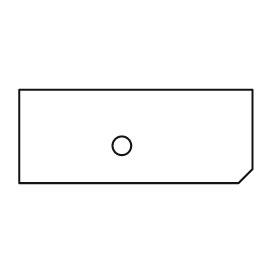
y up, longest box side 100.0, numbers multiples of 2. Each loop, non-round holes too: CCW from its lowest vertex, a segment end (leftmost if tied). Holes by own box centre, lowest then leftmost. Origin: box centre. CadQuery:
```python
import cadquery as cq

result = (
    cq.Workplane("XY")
    .moveTo(-50.0, -20.0)
    .lineTo(44.0, -20.0)
    .lineTo(50.0, -14.0)
    .lineTo(50.0, 20.0)
    .lineTo(-50.0, 20.0)
    .close()
    .moveTo(-6.0, -4.0)
    .circle(4.0)
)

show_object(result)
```